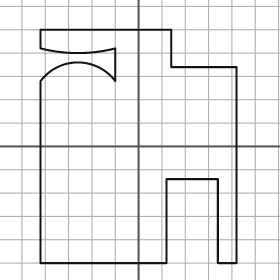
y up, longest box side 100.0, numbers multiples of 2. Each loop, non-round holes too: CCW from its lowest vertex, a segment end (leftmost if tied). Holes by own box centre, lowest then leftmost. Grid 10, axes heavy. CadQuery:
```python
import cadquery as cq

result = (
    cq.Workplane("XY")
    .moveTo(-42.0, -50.0)
    .lineTo(12.0, -50.0)
    .lineTo(12.0, -14.0)
    .lineTo(34.0, -14.0)
    .lineTo(34.0, -50.0)
    .lineTo(42.0, -50.0)
    .lineTo(42.0, 34.0)
    .lineTo(14.0, 34.0)
    .lineTo(14.0, 50.0)
    .lineTo(-42.0, 50.0)
    .lineTo(-42.0, 42.0)
    .threePointArc((-26.0, 40.0), (-10.0, 42.0))
    .lineTo(-10.0, 28.0)
    .threePointArc((-26.0, 36.0), (-42.0, 28.0))
    .close()
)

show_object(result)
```